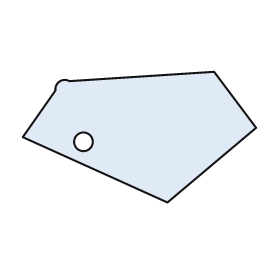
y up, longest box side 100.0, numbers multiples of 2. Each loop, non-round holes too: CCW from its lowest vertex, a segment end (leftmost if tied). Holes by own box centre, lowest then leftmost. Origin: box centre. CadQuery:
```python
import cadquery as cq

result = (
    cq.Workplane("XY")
    .moveTo(12.0, -28.0)
    .lineTo(50.0, 4.0)
    .lineTo(32.0, 28.0)
    .lineTo(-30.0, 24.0)
    .threePointArc((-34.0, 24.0), (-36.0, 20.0))
    .lineTo(-50.0, 0.0)
    .close()
    .moveTo(-24.0, -2.0)
    .circle(4.0)
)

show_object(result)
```